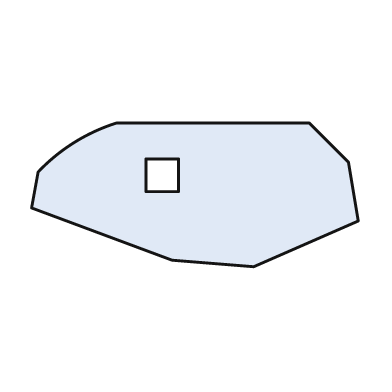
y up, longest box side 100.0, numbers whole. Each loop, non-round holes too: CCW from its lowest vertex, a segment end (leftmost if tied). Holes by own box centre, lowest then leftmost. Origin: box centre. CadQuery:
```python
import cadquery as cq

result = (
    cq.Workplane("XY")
    .moveTo(18.0, -22.0)
    .lineTo(50.0, -8.0)
    .lineTo(47.0, 10.0)
    .lineTo(35.0, 22.0)
    .lineTo(-24.0, 22.0)
    .threePointArc((-37.0, 16.0), (-48.0, 7.0))
    .lineTo(-50.0, -4.0)
    .lineTo(-7.0, -20.0)
    .close()
    .moveTo(-15.0, 1.0)
    .lineTo(-5.0, 1.0)
    .lineTo(-5.0, 11.0)
    .lineTo(-15.0, 11.0)
    .close()
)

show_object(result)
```